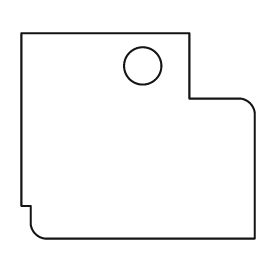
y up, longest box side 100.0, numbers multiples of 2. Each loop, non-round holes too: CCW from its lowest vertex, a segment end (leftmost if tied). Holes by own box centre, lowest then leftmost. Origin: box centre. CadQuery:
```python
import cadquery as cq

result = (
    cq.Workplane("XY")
    .moveTo(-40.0, -44.0)
    .lineTo(50.0, -44.0)
    .lineTo(50.0, 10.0)
    .threePointArc((48.0, 14.0), (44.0, 16.0))
    .lineTo(22.0, 16.0)
    .lineTo(22.0, 44.0)
    .lineTo(-50.0, 44.0)
    .lineTo(-50.0, -30.0)
    .lineTo(-46.0, -30.0)
    .lineTo(-46.0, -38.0)
    .threePointArc((-44.0, -42.0), (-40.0, -44.0))
    .close()
    .moveTo(2.0, 30.0)
    .circle(8.0)
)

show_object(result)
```